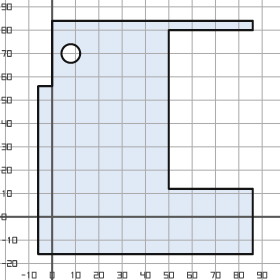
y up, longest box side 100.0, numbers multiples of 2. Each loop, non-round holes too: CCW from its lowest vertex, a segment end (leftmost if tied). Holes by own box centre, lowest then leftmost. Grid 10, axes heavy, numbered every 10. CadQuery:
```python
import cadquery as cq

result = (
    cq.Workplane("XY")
    .moveTo(-6.0, -16.0)
    .lineTo(86.0, -16.0)
    .lineTo(86.0, 12.0)
    .lineTo(50.0, 12.0)
    .lineTo(50.0, 80.0)
    .lineTo(86.0, 80.0)
    .lineTo(86.0, 84.0)
    .lineTo(0.0, 84.0)
    .lineTo(0.0, 56.0)
    .lineTo(-6.0, 56.0)
    .close()
    .moveTo(8.0, 70.0)
    .circle(4.0)
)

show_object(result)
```